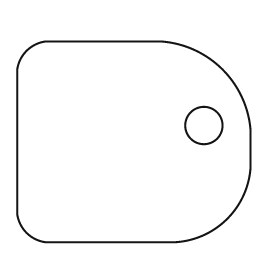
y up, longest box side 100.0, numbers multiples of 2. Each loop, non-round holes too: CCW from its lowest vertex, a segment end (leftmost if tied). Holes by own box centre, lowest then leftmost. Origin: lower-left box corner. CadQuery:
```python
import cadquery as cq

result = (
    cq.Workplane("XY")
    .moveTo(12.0, 0.0)
    .lineTo(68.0, 0.0)
    .threePointArc((90.0, 10.0), (100.0, 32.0))
    .lineTo(100.0, 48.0)
    .threePointArc((88.0, 74.0), (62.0, 86.0))
    .lineTo(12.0, 86.0)
    .threePointArc((4.0, 82.0), (0.0, 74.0))
    .lineTo(0.0, 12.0)
    .threePointArc((4.0, 4.0), (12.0, 0.0))
    .close()
    .moveTo(80.0, 50.0)
    .circle(8.0)
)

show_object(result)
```